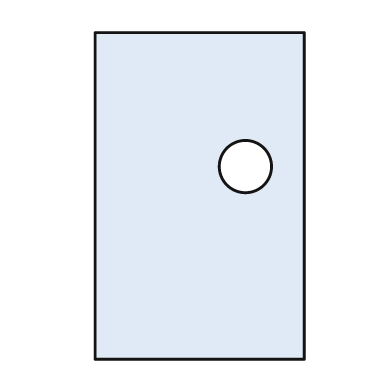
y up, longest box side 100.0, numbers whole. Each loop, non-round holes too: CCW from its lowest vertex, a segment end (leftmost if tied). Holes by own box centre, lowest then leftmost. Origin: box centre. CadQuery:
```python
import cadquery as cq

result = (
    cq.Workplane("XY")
    .moveTo(-32.0, -50.0)
    .lineTo(32.0, -50.0)
    .lineTo(32.0, 50.0)
    .lineTo(-32.0, 50.0)
    .close()
    .moveTo(14.0, 9.0)
    .circle(8.0)
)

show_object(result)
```